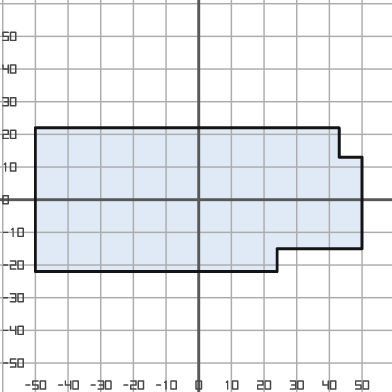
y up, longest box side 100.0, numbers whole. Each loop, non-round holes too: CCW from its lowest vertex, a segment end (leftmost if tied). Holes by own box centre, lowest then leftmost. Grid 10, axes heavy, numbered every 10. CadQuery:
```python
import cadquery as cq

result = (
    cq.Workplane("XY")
    .moveTo(-50.0, -22.0)
    .lineTo(24.0, -22.0)
    .lineTo(24.0, -15.0)
    .lineTo(50.0, -15.0)
    .lineTo(50.0, 13.0)
    .lineTo(43.0, 13.0)
    .lineTo(43.0, 22.0)
    .lineTo(-50.0, 22.0)
    .close()
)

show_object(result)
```